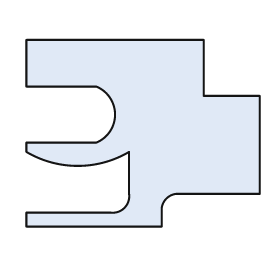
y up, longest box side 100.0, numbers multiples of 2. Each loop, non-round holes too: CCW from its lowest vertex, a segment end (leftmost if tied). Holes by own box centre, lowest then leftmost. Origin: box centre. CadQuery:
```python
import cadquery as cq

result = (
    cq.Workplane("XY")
    .moveTo(-50.0, -40.0)
    .lineTo(8.0, -40.0)
    .lineTo(8.0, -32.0)
    .threePointArc((10.0, -28.0), (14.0, -26.0))
    .lineTo(50.0, -26.0)
    .lineTo(50.0, 16.0)
    .lineTo(26.0, 16.0)
    .lineTo(26.0, 40.0)
    .lineTo(-50.0, 40.0)
    .lineTo(-50.0, 20.0)
    .lineTo(-20.0, 20.0)
    .threePointArc((-12.0, 8.0), (-20.0, -4.0))
    .lineTo(-50.0, -4.0)
    .lineTo(-50.0, -8.0)
    .threePointArc((-28.0, -14.0), (-6.0, -8.0))
    .lineTo(-6.0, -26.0)
    .threePointArc((-8.0, -32.0), (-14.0, -34.0))
    .lineTo(-50.0, -34.0)
    .close()
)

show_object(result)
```